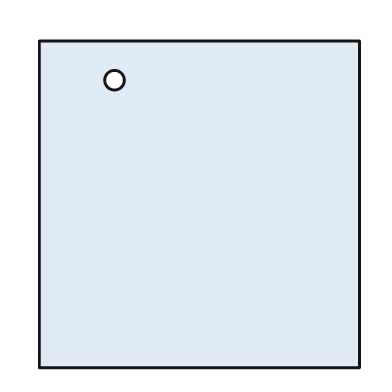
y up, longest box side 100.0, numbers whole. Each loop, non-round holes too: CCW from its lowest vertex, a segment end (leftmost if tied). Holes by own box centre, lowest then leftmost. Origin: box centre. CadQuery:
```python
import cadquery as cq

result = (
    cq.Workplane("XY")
    .moveTo(-49.0, -50.0)
    .lineTo(49.0, -50.0)
    .lineTo(49.0, 50.0)
    .lineTo(-49.0, 50.0)
    .close()
    .moveTo(-26.0, 38.0)
    .circle(3.0)
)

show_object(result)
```